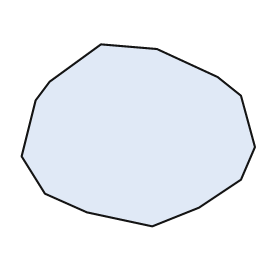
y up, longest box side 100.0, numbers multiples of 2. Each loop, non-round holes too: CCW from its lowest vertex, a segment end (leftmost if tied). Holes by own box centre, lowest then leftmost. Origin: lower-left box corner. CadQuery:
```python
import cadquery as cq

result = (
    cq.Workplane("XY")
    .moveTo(56.0, 0.0)
    .lineTo(76.0, 8.0)
    .lineTo(94.0, 20.0)
    .lineTo(100.0, 34.0)
    .lineTo(94.0, 56.0)
    .lineTo(84.0, 64.0)
    .lineTo(58.0, 76.0)
    .lineTo(34.0, 78.0)
    .lineTo(12.0, 62.0)
    .lineTo(6.0, 54.0)
    .lineTo(0.0, 30.0)
    .lineTo(10.0, 14.0)
    .lineTo(28.0, 6.0)
    .close()
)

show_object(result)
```